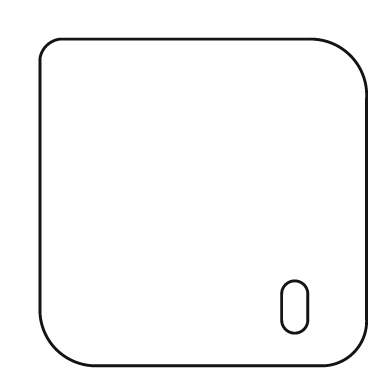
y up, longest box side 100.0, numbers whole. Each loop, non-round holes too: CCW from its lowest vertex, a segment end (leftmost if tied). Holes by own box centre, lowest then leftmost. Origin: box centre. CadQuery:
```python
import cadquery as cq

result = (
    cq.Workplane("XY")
    .moveTo(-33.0, -50.0)
    .lineTo(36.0, -50.0)
    .threePointArc((46.0, -46.0), (50.0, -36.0))
    .lineTo(50.0, 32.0)
    .threePointArc((45.0, 45.0), (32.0, 50.0))
    .lineTo(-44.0, 50.0)
    .threePointArc((-48.0, 48.0), (-50.0, 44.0))
    .lineTo(-50.0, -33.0)
    .threePointArc((-45.0, -45.0), (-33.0, -50.0))
    .close()
    .moveTo(24.0, -36.0)
    .threePointArc((28.0, -40.0), (32.0, -36.0))
    .lineTo(32.0, -28.0)
    .threePointArc((28.0, -24.0), (24.0, -28.0))
    .close()
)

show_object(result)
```